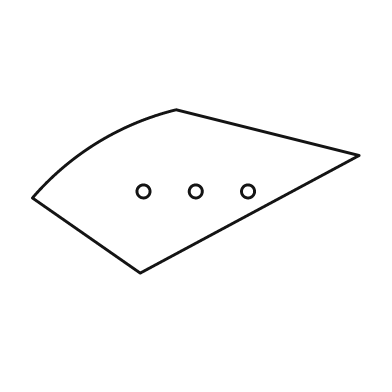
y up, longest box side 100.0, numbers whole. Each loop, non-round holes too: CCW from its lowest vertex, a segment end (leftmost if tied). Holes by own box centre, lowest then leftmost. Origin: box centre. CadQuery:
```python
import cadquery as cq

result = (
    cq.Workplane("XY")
    .moveTo(-17.0, -25.0)
    .lineTo(50.0, 11.0)
    .lineTo(-6.0, 25.0)
    .threePointArc((-30.0, 15.0), (-50.0, -2.0))
    .close()
    .moveTo(-16.0, 0.0)
    .circle(2.0)
    .moveTo(0.0, 0.0)
    .circle(2.0)
    .moveTo(16.0, 0.0)
    .circle(2.0)
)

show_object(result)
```